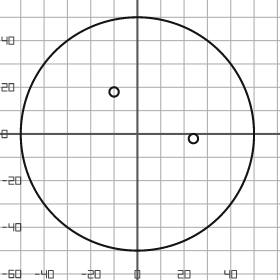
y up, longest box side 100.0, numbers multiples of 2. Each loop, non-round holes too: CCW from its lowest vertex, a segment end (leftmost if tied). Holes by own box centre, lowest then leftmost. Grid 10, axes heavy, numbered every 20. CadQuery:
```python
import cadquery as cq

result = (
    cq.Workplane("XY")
    .moveTo(0.0, 0.0)
    .circle(50.0)
    .moveTo(24.0, -2.0)
    .circle(2.0)
    .moveTo(-10.0, 18.0)
    .circle(2.0)
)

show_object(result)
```